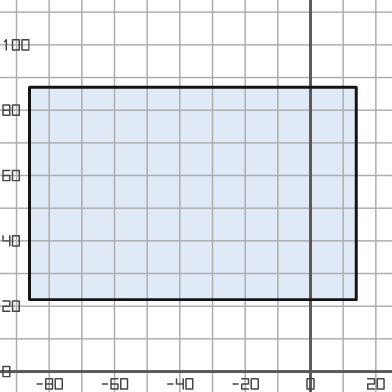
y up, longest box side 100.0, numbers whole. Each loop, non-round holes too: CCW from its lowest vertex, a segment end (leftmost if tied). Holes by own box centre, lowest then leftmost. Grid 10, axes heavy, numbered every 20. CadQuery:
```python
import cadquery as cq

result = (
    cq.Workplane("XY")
    .moveTo(-86.0, 22.0)
    .lineTo(14.0, 22.0)
    .lineTo(14.0, 87.0)
    .lineTo(-86.0, 87.0)
    .close()
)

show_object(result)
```